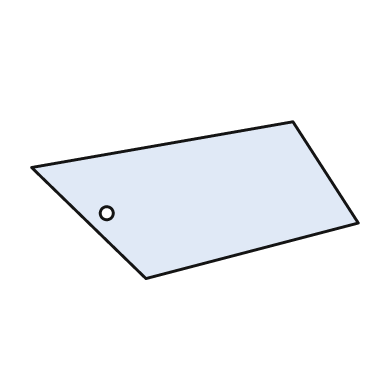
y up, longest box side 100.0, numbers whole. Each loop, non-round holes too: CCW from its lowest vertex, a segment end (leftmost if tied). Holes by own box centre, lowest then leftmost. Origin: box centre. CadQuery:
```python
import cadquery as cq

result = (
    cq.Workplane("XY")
    .moveTo(-15.0, -24.0)
    .lineTo(50.0, -7.0)
    .lineTo(30.0, 24.0)
    .lineTo(-50.0, 10.0)
    .close()
    .moveTo(-27.0, -4.0)
    .circle(2.0)
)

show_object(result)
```